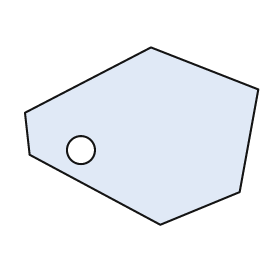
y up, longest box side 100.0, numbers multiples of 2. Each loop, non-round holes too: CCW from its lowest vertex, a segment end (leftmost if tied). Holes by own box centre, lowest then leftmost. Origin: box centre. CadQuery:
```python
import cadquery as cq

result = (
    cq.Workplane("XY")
    .moveTo(8.0, -38.0)
    .lineTo(42.0, -24.0)
    .lineTo(50.0, 20.0)
    .lineTo(4.0, 38.0)
    .lineTo(-50.0, 10.0)
    .lineTo(-48.0, -8.0)
    .close()
    .moveTo(-26.0, -6.0)
    .circle(6.0)
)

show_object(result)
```